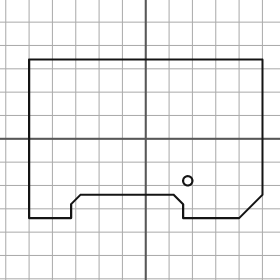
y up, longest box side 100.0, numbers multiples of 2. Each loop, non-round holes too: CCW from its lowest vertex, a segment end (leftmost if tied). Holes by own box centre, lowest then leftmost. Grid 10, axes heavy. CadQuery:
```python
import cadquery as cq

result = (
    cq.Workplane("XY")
    .moveTo(-50.0, -34.0)
    .lineTo(-32.0, -34.0)
    .lineTo(-32.0, -28.0)
    .lineTo(-28.0, -24.0)
    .lineTo(12.0, -24.0)
    .lineTo(16.0, -28.0)
    .lineTo(16.0, -34.0)
    .lineTo(40.0, -34.0)
    .lineTo(50.0, -24.0)
    .lineTo(50.0, 34.0)
    .lineTo(-50.0, 34.0)
    .close()
    .moveTo(18.0, -18.0)
    .circle(2.0)
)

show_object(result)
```